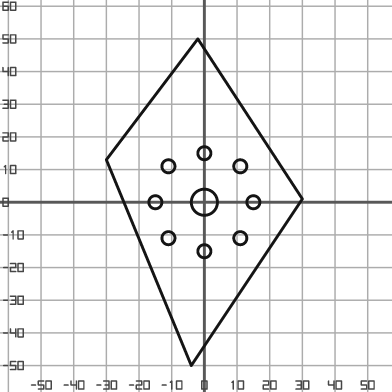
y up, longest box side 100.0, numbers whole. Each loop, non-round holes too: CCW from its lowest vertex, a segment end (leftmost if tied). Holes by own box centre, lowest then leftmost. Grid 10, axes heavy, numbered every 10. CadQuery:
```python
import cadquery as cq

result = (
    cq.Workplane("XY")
    .moveTo(-4.0, -50.0)
    .lineTo(30.0, 1.0)
    .lineTo(-2.0, 50.0)
    .lineTo(-30.0, 13.0)
    .close()
    .moveTo(0.0, -15.0)
    .circle(2.0)
    .moveTo(-11.0, -11.0)
    .circle(2.0)
    .moveTo(11.0, -11.0)
    .circle(2.0)
    .moveTo(-15.0, 0.0)
    .circle(2.0)
    .moveTo(0.0, 0.0)
    .circle(4.0)
    .moveTo(15.0, 0.0)
    .circle(2.0)
    .moveTo(-11.0, 11.0)
    .circle(2.0)
    .moveTo(11.0, 11.0)
    .circle(2.0)
    .moveTo(0.0, 15.0)
    .circle(2.0)
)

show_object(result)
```